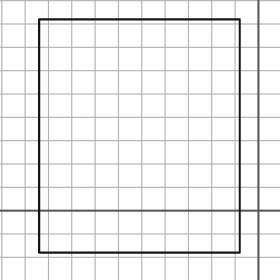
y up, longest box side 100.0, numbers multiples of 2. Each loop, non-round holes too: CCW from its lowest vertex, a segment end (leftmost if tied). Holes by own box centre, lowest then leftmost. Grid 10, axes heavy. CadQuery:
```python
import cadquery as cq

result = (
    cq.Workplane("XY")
    .moveTo(-94.0, -18.0)
    .lineTo(-8.0, -18.0)
    .lineTo(-8.0, 82.0)
    .lineTo(-94.0, 82.0)
    .close()
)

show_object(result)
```